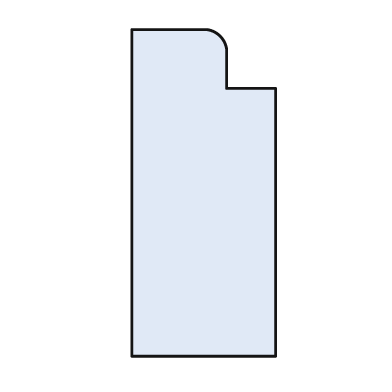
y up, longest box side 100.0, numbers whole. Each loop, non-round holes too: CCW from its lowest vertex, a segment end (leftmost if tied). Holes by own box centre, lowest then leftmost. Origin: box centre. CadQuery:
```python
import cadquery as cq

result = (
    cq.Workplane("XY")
    .moveTo(-22.0, -50.0)
    .lineTo(22.0, -50.0)
    .lineTo(22.0, 32.0)
    .lineTo(7.0, 32.0)
    .lineTo(7.0, 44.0)
    .threePointArc((5.0, 48.0), (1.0, 50.0))
    .lineTo(-22.0, 50.0)
    .close()
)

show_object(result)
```